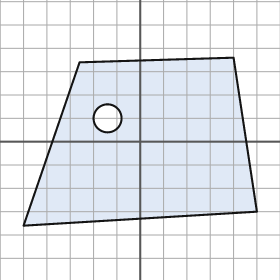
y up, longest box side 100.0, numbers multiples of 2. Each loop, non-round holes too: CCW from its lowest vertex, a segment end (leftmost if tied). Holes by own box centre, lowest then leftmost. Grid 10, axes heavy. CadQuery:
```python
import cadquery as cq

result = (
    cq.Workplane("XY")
    .moveTo(-50.0, -36.0)
    .lineTo(50.0, -30.0)
    .lineTo(40.0, 36.0)
    .lineTo(-26.0, 34.0)
    .close()
    .moveTo(-14.0, 10.0)
    .circle(6.0)
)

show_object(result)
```